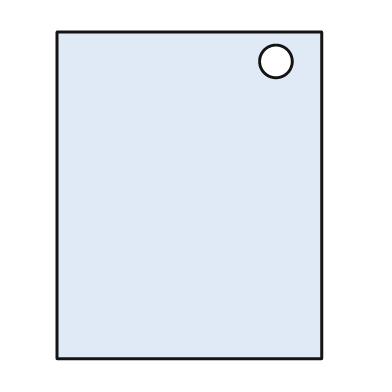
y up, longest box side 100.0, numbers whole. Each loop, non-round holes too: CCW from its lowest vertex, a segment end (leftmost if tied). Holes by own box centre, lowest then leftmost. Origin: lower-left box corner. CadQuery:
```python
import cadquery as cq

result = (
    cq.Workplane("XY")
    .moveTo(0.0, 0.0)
    .lineTo(81.0, 0.0)
    .lineTo(81.0, 100.0)
    .lineTo(0.0, 100.0)
    .close()
    .moveTo(67.0, 91.0)
    .circle(5.0)
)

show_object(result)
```